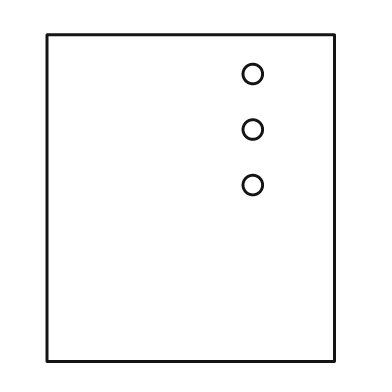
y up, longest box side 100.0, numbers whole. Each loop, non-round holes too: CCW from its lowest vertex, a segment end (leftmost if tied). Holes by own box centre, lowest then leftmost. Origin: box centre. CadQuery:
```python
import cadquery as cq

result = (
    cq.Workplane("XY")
    .moveTo(-44.0, -50.0)
    .lineTo(44.0, -50.0)
    .lineTo(44.0, 50.0)
    .lineTo(-44.0, 50.0)
    .close()
    .moveTo(19.0, 4.0)
    .circle(3.0)
    .moveTo(19.0, 21.0)
    .circle(3.0)
    .moveTo(19.0, 38.0)
    .circle(3.0)
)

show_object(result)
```